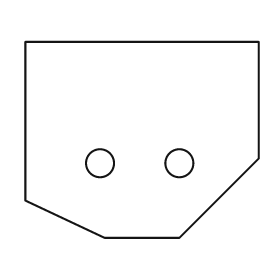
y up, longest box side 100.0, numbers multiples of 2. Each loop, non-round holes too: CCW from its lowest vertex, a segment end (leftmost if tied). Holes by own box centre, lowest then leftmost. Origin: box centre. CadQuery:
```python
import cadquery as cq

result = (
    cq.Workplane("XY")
    .moveTo(-16.0, -42.0)
    .lineTo(16.0, -42.0)
    .lineTo(50.0, -8.0)
    .lineTo(50.0, 42.0)
    .lineTo(-50.0, 42.0)
    .lineTo(-50.0, -26.0)
    .close()
    .moveTo(-18.0, -10.0)
    .circle(6.0)
    .moveTo(16.0, -10.0)
    .circle(6.0)
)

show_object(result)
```